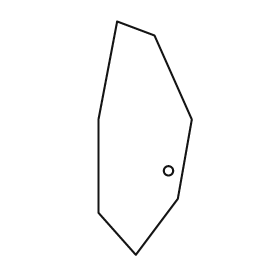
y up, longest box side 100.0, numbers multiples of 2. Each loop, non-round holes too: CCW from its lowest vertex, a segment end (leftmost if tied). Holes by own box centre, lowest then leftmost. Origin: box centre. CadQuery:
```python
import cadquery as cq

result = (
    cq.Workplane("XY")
    .moveTo(-4.0, -50.0)
    .lineTo(14.0, -26.0)
    .lineTo(20.0, 8.0)
    .lineTo(4.0, 44.0)
    .lineTo(-12.0, 50.0)
    .lineTo(-20.0, 8.0)
    .lineTo(-20.0, -32.0)
    .close()
    .moveTo(10.0, -14.0)
    .circle(2.0)
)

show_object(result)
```